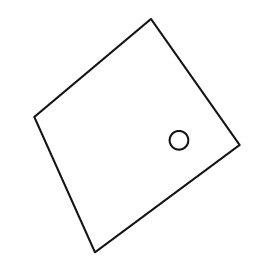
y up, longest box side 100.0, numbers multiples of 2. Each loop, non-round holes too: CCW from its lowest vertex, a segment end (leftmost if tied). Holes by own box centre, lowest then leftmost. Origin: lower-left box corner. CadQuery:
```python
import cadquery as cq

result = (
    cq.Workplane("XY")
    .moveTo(26.0, 0.0)
    .lineTo(88.0, 46.0)
    .lineTo(50.0, 100.0)
    .lineTo(0.0, 58.0)
    .close()
    .moveTo(62.0, 48.0)
    .circle(4.0)
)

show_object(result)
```